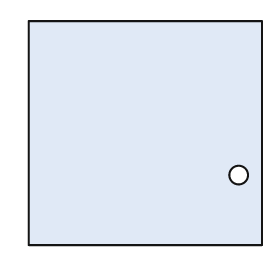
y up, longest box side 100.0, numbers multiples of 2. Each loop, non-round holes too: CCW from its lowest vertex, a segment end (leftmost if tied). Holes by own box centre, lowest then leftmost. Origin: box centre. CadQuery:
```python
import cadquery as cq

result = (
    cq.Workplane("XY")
    .moveTo(-50.0, -48.0)
    .lineTo(50.0, -48.0)
    .lineTo(50.0, 48.0)
    .lineTo(-50.0, 48.0)
    .close()
    .moveTo(40.0, -18.0)
    .circle(4.0)
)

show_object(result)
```